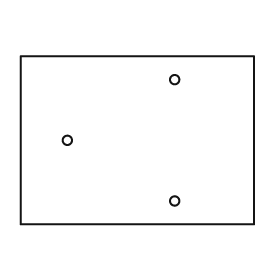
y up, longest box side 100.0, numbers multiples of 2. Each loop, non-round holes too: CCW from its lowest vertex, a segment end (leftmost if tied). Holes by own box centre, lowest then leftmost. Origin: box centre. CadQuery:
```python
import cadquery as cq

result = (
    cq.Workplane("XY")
    .moveTo(-50.0, -36.0)
    .lineTo(50.0, -36.0)
    .lineTo(50.0, 36.0)
    .lineTo(-50.0, 36.0)
    .close()
    .moveTo(16.0, -26.0)
    .circle(2.0)
    .moveTo(-30.0, 0.0)
    .circle(2.0)
    .moveTo(16.0, 26.0)
    .circle(2.0)
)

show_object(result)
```